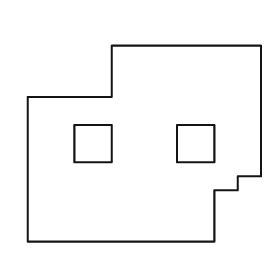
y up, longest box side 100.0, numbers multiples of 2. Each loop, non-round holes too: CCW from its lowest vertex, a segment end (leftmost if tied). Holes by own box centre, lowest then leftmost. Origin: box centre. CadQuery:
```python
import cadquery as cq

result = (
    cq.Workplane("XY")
    .moveTo(-50.0, -42.0)
    .lineTo(30.0, -42.0)
    .lineTo(30.0, -20.0)
    .lineTo(40.0, -20.0)
    .lineTo(40.0, -14.0)
    .lineTo(50.0, -14.0)
    .lineTo(50.0, 42.0)
    .lineTo(-14.0, 42.0)
    .lineTo(-14.0, 20.0)
    .lineTo(-50.0, 20.0)
    .close()
    .moveTo(-30.0, -8.0)
    .lineTo(-14.0, -8.0)
    .lineTo(-14.0, 8.0)
    .lineTo(-30.0, 8.0)
    .close()
    .moveTo(14.0, -8.0)
    .lineTo(30.0, -8.0)
    .lineTo(30.0, 8.0)
    .lineTo(14.0, 8.0)
    .close()
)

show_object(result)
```